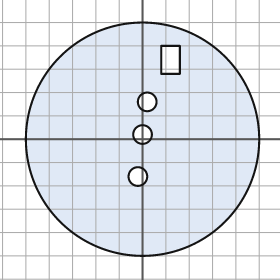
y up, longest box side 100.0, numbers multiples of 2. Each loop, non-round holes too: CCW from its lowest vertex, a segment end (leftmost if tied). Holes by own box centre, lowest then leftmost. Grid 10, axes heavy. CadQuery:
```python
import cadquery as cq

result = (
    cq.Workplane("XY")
    .moveTo(0.0, 0.0)
    .circle(50.0)
    .moveTo(-2.0, -16.0)
    .circle(4.0)
    .moveTo(0.0, 2.0)
    .circle(4.0)
    .moveTo(2.0, 16.0)
    .circle(4.0)
    .moveTo(8.0, 28.0)
    .lineTo(16.0, 28.0)
    .lineTo(16.0, 40.0)
    .lineTo(8.0, 40.0)
    .close()
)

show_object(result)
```